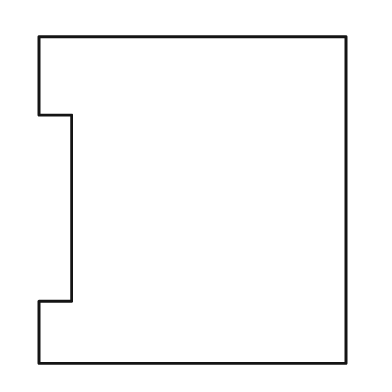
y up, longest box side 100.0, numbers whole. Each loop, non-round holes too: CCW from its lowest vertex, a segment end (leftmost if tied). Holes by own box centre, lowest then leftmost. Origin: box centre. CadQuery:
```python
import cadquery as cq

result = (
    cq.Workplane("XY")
    .moveTo(-47.0, -50.0)
    .lineTo(47.0, -50.0)
    .lineTo(47.0, 50.0)
    .lineTo(-47.0, 50.0)
    .lineTo(-47.0, 26.0)
    .lineTo(-37.0, 26.0)
    .lineTo(-37.0, -31.0)
    .lineTo(-47.0, -31.0)
    .close()
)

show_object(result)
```